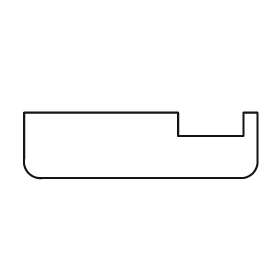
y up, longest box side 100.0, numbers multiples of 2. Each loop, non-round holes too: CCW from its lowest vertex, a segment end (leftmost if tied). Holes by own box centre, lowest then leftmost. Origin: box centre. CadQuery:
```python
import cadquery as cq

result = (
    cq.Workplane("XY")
    .moveTo(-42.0, -14.0)
    .lineTo(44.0, -14.0)
    .threePointArc((48.0, -12.0), (50.0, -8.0))
    .lineTo(50.0, 14.0)
    .lineTo(44.0, 14.0)
    .lineTo(44.0, 4.0)
    .lineTo(16.0, 4.0)
    .lineTo(16.0, 14.0)
    .lineTo(-50.0, 14.0)
    .lineTo(-50.0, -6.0)
    .threePointArc((-48.0, -12.0), (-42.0, -14.0))
    .close()
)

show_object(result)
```